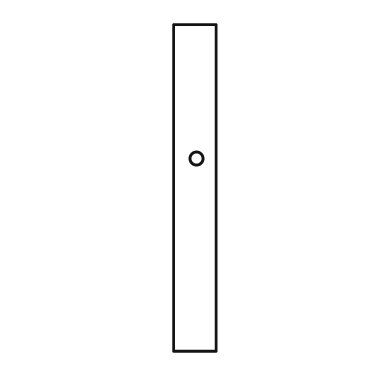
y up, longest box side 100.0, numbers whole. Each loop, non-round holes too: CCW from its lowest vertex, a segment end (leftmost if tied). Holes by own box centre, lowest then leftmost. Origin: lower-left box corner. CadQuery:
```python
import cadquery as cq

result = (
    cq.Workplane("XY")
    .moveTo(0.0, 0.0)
    .lineTo(13.0, 0.0)
    .lineTo(13.0, 100.0)
    .lineTo(0.0, 100.0)
    .close()
    .moveTo(7.0, 59.0)
    .circle(2.0)
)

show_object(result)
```